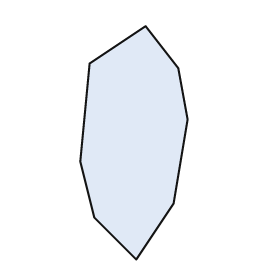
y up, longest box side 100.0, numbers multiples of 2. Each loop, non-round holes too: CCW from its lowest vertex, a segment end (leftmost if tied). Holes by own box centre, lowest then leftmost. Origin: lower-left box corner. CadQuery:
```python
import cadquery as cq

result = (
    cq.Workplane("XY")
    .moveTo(24.0, 0.0)
    .lineTo(40.0, 24.0)
    .lineTo(46.0, 60.0)
    .lineTo(42.0, 82.0)
    .lineTo(28.0, 100.0)
    .lineTo(4.0, 84.0)
    .lineTo(0.0, 42.0)
    .lineTo(6.0, 18.0)
    .close()
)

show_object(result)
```